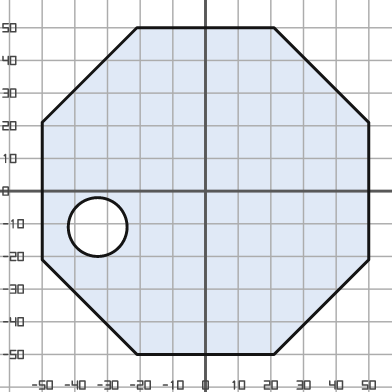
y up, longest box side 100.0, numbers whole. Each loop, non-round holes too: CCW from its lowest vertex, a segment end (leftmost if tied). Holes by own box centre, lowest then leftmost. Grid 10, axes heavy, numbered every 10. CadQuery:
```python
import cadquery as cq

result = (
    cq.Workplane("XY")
    .moveTo(-21.0, -50.0)
    .lineTo(21.0, -50.0)
    .lineTo(50.0, -21.0)
    .lineTo(50.0, 21.0)
    .lineTo(21.0, 50.0)
    .lineTo(-21.0, 50.0)
    .lineTo(-50.0, 21.0)
    .lineTo(-50.0, -21.0)
    .close()
    .moveTo(-33.0, -11.0)
    .circle(9.0)
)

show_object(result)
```